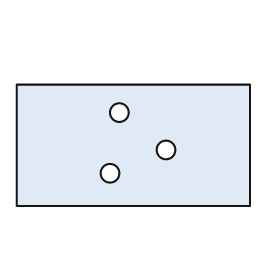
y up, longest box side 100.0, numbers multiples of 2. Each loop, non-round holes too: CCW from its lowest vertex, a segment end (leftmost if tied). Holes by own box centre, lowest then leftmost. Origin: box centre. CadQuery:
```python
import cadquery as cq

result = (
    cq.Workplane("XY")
    .moveTo(-50.0, -26.0)
    .lineTo(50.0, -26.0)
    .lineTo(50.0, 26.0)
    .lineTo(-50.0, 26.0)
    .close()
    .moveTo(-10.0, -12.0)
    .circle(4.0)
    .moveTo(14.0, -2.0)
    .circle(4.0)
    .moveTo(-6.0, 14.0)
    .circle(4.0)
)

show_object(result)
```